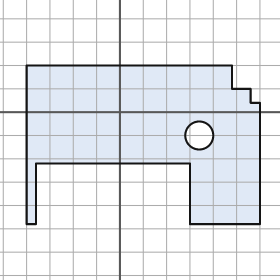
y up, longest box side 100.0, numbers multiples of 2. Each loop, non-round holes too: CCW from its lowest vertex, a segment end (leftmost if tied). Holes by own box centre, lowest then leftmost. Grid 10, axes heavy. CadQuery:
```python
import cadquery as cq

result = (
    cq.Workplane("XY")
    .moveTo(-40.0, -48.0)
    .lineTo(-36.0, -48.0)
    .lineTo(-36.0, -22.0)
    .lineTo(30.0, -22.0)
    .lineTo(30.0, -48.0)
    .lineTo(60.0, -48.0)
    .lineTo(60.0, 4.0)
    .lineTo(56.0, 4.0)
    .lineTo(56.0, 10.0)
    .lineTo(48.0, 10.0)
    .lineTo(48.0, 20.0)
    .lineTo(-40.0, 20.0)
    .close()
    .moveTo(34.0, -10.0)
    .circle(6.0)
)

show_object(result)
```